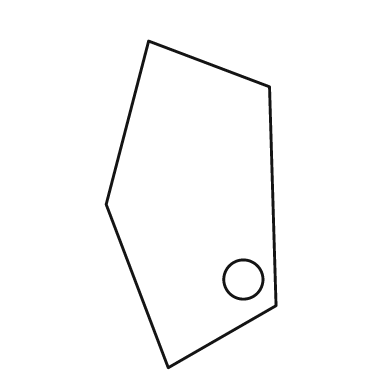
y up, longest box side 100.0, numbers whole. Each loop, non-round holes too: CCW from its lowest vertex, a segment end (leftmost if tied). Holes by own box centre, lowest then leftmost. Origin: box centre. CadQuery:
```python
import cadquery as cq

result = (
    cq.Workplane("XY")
    .moveTo(-7.0, -50.0)
    .lineTo(26.0, -31.0)
    .lineTo(24.0, 36.0)
    .lineTo(-13.0, 50.0)
    .lineTo(-26.0, 0.0)
    .close()
    .moveTo(16.0, -23.0)
    .circle(6.0)
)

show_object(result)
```